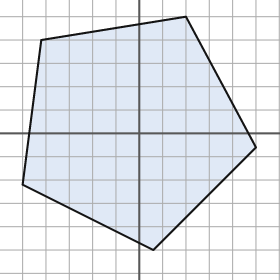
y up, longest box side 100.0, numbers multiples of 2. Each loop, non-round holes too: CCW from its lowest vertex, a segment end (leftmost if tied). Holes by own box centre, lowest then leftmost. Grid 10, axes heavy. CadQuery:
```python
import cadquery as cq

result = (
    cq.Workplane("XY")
    .moveTo(6.0, -50.0)
    .lineTo(50.0, -6.0)
    .lineTo(20.0, 50.0)
    .lineTo(-42.0, 40.0)
    .lineTo(-50.0, -22.0)
    .close()
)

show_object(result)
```